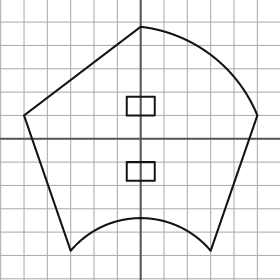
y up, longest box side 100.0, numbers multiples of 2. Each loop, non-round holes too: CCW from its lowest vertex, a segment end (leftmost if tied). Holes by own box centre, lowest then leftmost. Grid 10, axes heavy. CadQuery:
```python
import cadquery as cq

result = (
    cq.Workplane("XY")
    .moveTo(-30.0, -48.0)
    .threePointArc((0.0, -34.0), (30.0, -48.0))
    .lineTo(50.0, 10.0)
    .threePointArc((30.0, 36.0), (0.0, 48.0))
    .lineTo(-50.0, 10.0)
    .close()
    .moveTo(-6.0, -18.0)
    .lineTo(6.0, -18.0)
    .lineTo(6.0, -10.0)
    .lineTo(-6.0, -10.0)
    .close()
    .moveTo(-6.0, 10.0)
    .lineTo(6.0, 10.0)
    .lineTo(6.0, 18.0)
    .lineTo(-6.0, 18.0)
    .close()
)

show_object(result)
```